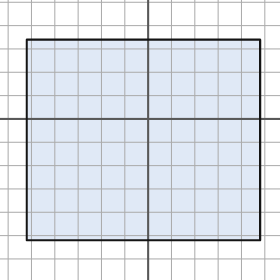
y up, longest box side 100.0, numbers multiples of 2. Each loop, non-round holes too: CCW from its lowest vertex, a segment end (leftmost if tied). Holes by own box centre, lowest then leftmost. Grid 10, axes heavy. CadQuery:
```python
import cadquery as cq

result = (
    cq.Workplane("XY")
    .moveTo(-52.0, -52.0)
    .lineTo(48.0, -52.0)
    .lineTo(48.0, 34.0)
    .lineTo(-52.0, 34.0)
    .close()
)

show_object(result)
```